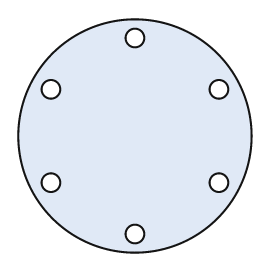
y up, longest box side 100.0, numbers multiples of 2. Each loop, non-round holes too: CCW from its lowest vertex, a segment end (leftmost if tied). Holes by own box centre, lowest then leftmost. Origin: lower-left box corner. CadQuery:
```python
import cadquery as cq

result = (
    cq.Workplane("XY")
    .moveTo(50.0, 50.0)
    .circle(50.0)
    .moveTo(50.0, 8.0)
    .circle(4.0)
    .moveTo(14.0, 30.0)
    .circle(4.0)
    .moveTo(86.0, 30.0)
    .circle(4.0)
    .moveTo(14.0, 70.0)
    .circle(4.0)
    .moveTo(86.0, 70.0)
    .circle(4.0)
    .moveTo(50.0, 92.0)
    .circle(4.0)
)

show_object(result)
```